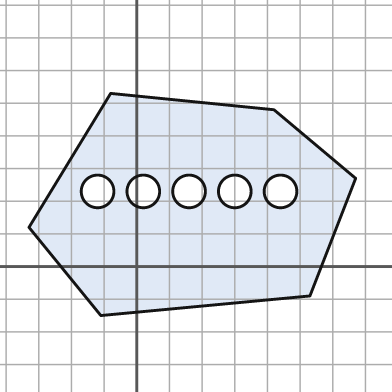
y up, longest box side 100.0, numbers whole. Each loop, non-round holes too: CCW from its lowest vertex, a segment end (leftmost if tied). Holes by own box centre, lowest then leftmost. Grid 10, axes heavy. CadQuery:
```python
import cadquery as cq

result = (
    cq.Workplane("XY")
    .moveTo(-11.0, -15.0)
    .lineTo(53.0, -9.0)
    .lineTo(67.0, 27.0)
    .lineTo(42.0, 48.0)
    .lineTo(-8.0, 53.0)
    .lineTo(-33.0, 12.0)
    .close()
    .moveTo(-12.0, 23.0)
    .circle(5.0)
    .moveTo(2.0, 23.0)
    .circle(5.0)
    .moveTo(16.0, 23.0)
    .circle(5.0)
    .moveTo(30.0, 23.0)
    .circle(5.0)
    .moveTo(44.0, 23.0)
    .circle(5.0)
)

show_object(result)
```